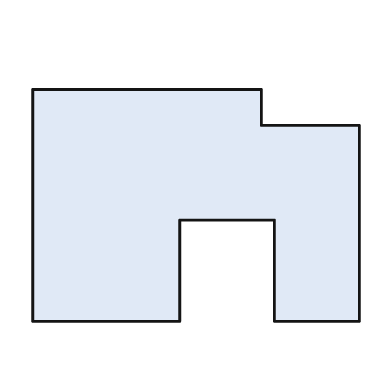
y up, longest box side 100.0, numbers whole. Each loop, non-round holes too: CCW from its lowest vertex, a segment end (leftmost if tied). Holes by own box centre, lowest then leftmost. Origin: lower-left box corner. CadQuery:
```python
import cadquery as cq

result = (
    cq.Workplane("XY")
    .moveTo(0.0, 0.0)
    .lineTo(45.0, 0.0)
    .lineTo(45.0, 31.0)
    .lineTo(74.0, 31.0)
    .lineTo(74.0, 0.0)
    .lineTo(100.0, 0.0)
    .lineTo(100.0, 60.0)
    .lineTo(70.0, 60.0)
    .lineTo(70.0, 71.0)
    .lineTo(0.0, 71.0)
    .close()
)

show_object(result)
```